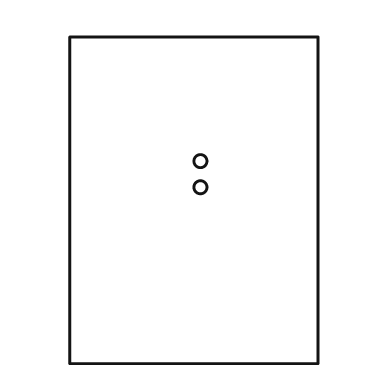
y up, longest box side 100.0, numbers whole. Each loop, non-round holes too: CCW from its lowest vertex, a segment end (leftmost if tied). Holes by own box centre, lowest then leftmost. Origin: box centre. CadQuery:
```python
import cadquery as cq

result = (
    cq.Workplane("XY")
    .moveTo(-38.0, -50.0)
    .lineTo(38.0, -50.0)
    .lineTo(38.0, 50.0)
    .lineTo(-38.0, 50.0)
    .close()
    .moveTo(2.0, 4.0)
    .circle(2.0)
    .moveTo(2.0, 12.0)
    .circle(2.0)
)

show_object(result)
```